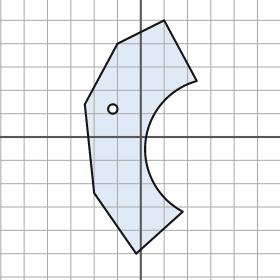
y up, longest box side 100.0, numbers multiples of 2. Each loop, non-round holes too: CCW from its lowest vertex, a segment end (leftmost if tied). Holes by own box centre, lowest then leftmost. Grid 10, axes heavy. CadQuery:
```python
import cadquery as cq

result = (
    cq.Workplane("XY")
    .moveTo(-2.0, -50.0)
    .lineTo(18.0, -32.0)
    .threePointArc((2.0, -2.0), (24.0, 24.0))
    .lineTo(10.0, 50.0)
    .lineTo(-10.0, 40.0)
    .lineTo(-24.0, 14.0)
    .lineTo(-20.0, -24.0)
    .close()
    .moveTo(-12.0, 12.0)
    .circle(2.0)
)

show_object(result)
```